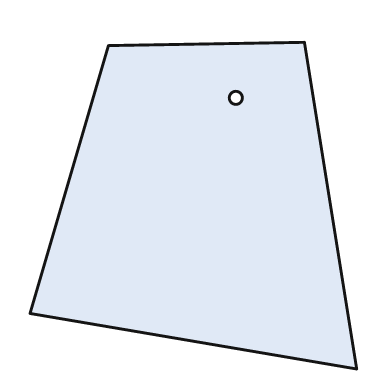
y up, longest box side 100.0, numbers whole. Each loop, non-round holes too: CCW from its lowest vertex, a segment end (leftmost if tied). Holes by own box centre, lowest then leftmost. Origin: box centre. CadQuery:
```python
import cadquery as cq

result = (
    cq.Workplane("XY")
    .moveTo(50.0, -50.0)
    .lineTo(34.0, 50.0)
    .lineTo(-26.0, 49.0)
    .lineTo(-50.0, -33.0)
    .close()
    .moveTo(13.0, 33.0)
    .circle(2.0)
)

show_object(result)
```